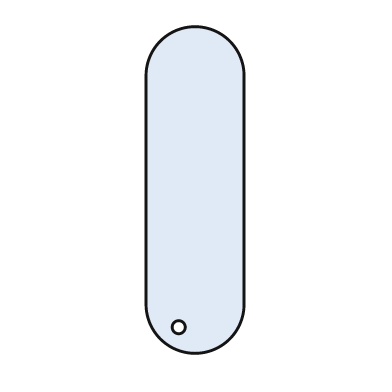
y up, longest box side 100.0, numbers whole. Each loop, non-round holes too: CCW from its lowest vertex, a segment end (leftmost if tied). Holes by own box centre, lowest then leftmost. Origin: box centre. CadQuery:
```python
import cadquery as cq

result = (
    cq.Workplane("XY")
    .moveTo(-15.0, -35.0)
    .threePointArc((0.0, -50.0), (15.0, -35.0))
    .lineTo(15.0, 35.0)
    .threePointArc((0.0, 50.0), (-15.0, 35.0))
    .close()
    .moveTo(-5.0, -42.0)
    .circle(2.0)
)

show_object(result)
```